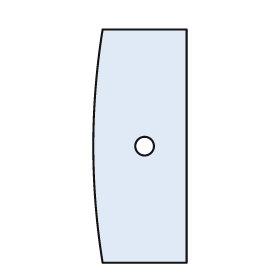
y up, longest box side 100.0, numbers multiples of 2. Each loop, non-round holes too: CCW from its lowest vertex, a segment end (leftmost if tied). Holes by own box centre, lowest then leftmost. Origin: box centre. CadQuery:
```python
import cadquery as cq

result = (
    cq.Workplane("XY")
    .moveTo(-16.0, -50.0)
    .lineTo(20.0, -50.0)
    .lineTo(20.0, 50.0)
    .lineTo(-16.0, 50.0)
    .threePointArc((-20.0, 0.0), (-16.0, -50.0))
    .close()
    .moveTo(2.0, 0.0)
    .circle(4.0)
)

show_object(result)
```